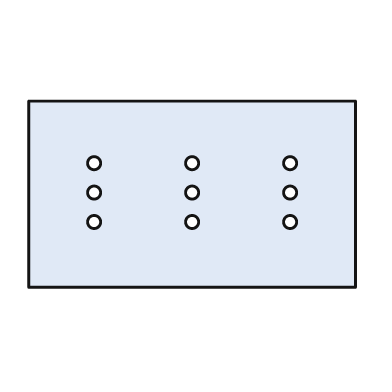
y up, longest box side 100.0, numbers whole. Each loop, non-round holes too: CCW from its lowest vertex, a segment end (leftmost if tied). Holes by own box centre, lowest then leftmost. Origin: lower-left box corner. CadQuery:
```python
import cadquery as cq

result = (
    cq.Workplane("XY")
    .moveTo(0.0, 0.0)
    .lineTo(100.0, 0.0)
    .lineTo(100.0, 57.0)
    .lineTo(0.0, 57.0)
    .close()
    .moveTo(20.0, 20.0)
    .circle(2.0)
    .moveTo(50.0, 20.0)
    .circle(2.0)
    .moveTo(80.0, 20.0)
    .circle(2.0)
    .moveTo(20.0, 29.0)
    .circle(2.0)
    .moveTo(50.0, 29.0)
    .circle(2.0)
    .moveTo(80.0, 29.0)
    .circle(2.0)
    .moveTo(20.0, 38.0)
    .circle(2.0)
    .moveTo(50.0, 38.0)
    .circle(2.0)
    .moveTo(80.0, 38.0)
    .circle(2.0)
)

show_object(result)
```